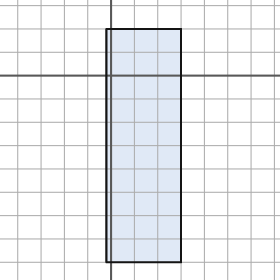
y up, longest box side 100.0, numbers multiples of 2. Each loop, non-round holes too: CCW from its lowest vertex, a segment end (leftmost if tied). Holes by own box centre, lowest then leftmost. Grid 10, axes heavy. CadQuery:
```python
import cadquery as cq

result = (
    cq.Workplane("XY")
    .moveTo(-2.0, -80.0)
    .lineTo(30.0, -80.0)
    .lineTo(30.0, 20.0)
    .lineTo(-2.0, 20.0)
    .close()
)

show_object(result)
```